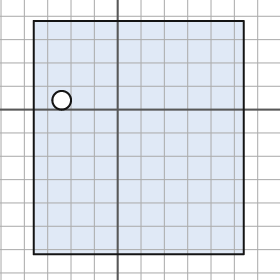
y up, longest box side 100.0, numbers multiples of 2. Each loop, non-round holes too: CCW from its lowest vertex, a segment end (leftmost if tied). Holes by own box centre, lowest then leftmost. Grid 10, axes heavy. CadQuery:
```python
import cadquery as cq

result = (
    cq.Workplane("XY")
    .moveTo(-36.0, -62.0)
    .lineTo(54.0, -62.0)
    .lineTo(54.0, 38.0)
    .lineTo(-36.0, 38.0)
    .close()
    .moveTo(-24.0, 4.0)
    .circle(4.0)
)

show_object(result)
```